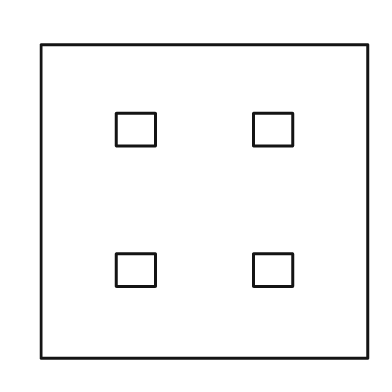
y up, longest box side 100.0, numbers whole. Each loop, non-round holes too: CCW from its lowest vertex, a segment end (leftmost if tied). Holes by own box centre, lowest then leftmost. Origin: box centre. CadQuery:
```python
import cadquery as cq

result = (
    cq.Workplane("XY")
    .moveTo(-50.0, -48.0)
    .lineTo(50.0, -48.0)
    .lineTo(50.0, 48.0)
    .lineTo(-50.0, 48.0)
    .close()
    .moveTo(-27.0, -26.0)
    .lineTo(-15.0, -26.0)
    .lineTo(-15.0, -16.0)
    .lineTo(-27.0, -16.0)
    .close()
    .moveTo(15.0, -26.0)
    .lineTo(27.0, -26.0)
    .lineTo(27.0, -16.0)
    .lineTo(15.0, -16.0)
    .close()
    .moveTo(-27.0, 17.0)
    .lineTo(-15.0, 17.0)
    .lineTo(-15.0, 27.0)
    .lineTo(-27.0, 27.0)
    .close()
    .moveTo(15.0, 17.0)
    .lineTo(27.0, 17.0)
    .lineTo(27.0, 27.0)
    .lineTo(15.0, 27.0)
    .close()
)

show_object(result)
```